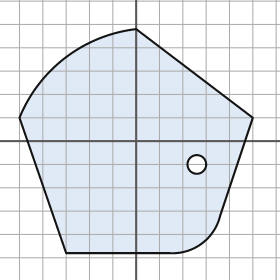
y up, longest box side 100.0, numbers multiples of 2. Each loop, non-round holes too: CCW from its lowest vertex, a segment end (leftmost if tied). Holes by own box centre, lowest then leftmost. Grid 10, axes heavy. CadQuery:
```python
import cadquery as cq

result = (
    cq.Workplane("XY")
    .moveTo(-30.0, -48.0)
    .lineTo(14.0, -48.0)
    .threePointArc((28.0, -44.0), (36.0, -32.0))
    .lineTo(50.0, 10.0)
    .lineTo(0.0, 48.0)
    .threePointArc((-30.0, 36.0), (-50.0, 10.0))
    .close()
    .moveTo(26.0, -10.0)
    .circle(4.0)
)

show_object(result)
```